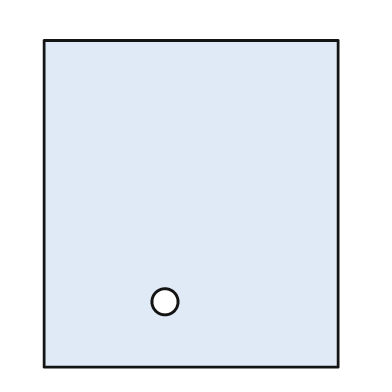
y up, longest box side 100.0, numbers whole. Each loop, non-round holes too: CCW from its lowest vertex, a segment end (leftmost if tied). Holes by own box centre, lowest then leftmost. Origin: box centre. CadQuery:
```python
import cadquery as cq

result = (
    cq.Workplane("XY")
    .moveTo(-45.0, -50.0)
    .lineTo(45.0, -50.0)
    .lineTo(45.0, 50.0)
    .lineTo(-45.0, 50.0)
    .close()
    .moveTo(-8.0, -30.0)
    .circle(4.0)
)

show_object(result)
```